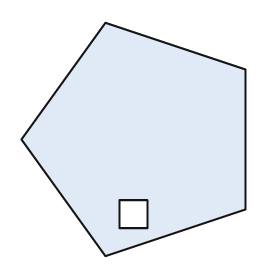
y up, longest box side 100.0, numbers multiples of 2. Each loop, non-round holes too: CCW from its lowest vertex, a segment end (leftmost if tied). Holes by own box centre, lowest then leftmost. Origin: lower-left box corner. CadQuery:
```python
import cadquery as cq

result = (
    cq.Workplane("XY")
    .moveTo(36.0, 0.0)
    .lineTo(96.0, 20.0)
    .lineTo(96.0, 80.0)
    .lineTo(36.0, 100.0)
    .lineTo(0.0, 50.0)
    .close()
    .moveTo(42.0, 12.0)
    .lineTo(54.0, 12.0)
    .lineTo(54.0, 24.0)
    .lineTo(42.0, 24.0)
    .close()
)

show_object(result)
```